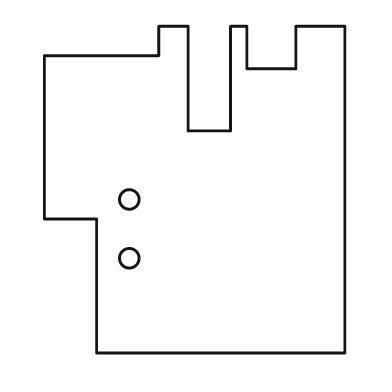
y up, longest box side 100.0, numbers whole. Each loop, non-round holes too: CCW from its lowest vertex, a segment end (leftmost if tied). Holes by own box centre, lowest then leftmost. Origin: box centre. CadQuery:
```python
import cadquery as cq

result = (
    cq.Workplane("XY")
    .moveTo(-30.0, -50.0)
    .lineTo(46.0, -50.0)
    .lineTo(46.0, 50.0)
    .lineTo(31.0, 50.0)
    .lineTo(31.0, 37.0)
    .lineTo(16.0, 37.0)
    .lineTo(16.0, 50.0)
    .lineTo(11.0, 50.0)
    .lineTo(11.0, 18.0)
    .lineTo(-2.0, 18.0)
    .lineTo(-2.0, 50.0)
    .lineTo(-11.0, 50.0)
    .lineTo(-11.0, 41.0)
    .lineTo(-46.0, 41.0)
    .lineTo(-46.0, -9.0)
    .lineTo(-30.0, -9.0)
    .close()
    .moveTo(-20.0, -21.0)
    .circle(3.0)
    .moveTo(-20.0, -3.0)
    .circle(3.0)
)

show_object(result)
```